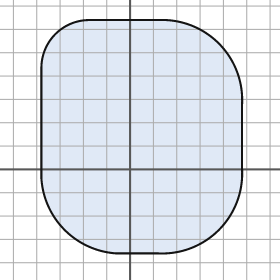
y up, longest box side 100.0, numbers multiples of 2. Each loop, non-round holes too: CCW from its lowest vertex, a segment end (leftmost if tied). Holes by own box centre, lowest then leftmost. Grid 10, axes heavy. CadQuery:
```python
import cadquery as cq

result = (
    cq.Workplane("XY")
    .moveTo(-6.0, -36.0)
    .lineTo(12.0, -36.0)
    .threePointArc((38.0, -26.0), (48.0, 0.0))
    .lineTo(48.0, 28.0)
    .threePointArc((38.0, 54.0), (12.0, 64.0))
    .lineTo(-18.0, 64.0)
    .threePointArc((-32.0, 58.0), (-38.0, 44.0))
    .lineTo(-38.0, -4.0)
    .threePointArc((-28.0, -26.0), (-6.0, -36.0))
    .close()
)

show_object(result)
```